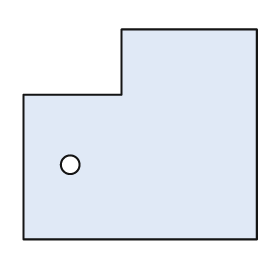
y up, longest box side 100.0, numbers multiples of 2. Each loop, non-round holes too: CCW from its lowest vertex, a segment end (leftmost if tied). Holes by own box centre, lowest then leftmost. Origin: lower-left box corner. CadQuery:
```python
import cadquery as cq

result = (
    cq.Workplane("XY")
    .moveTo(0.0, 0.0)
    .lineTo(100.0, 0.0)
    .lineTo(100.0, 90.0)
    .lineTo(42.0, 90.0)
    .lineTo(42.0, 62.0)
    .lineTo(0.0, 62.0)
    .close()
    .moveTo(20.0, 32.0)
    .circle(4.0)
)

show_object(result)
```